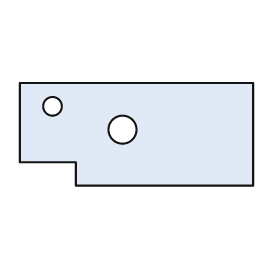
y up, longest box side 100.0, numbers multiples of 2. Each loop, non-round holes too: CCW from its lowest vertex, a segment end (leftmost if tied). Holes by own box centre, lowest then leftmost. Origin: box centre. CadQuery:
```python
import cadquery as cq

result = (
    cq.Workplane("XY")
    .moveTo(-26.0, -22.0)
    .lineTo(50.0, -22.0)
    .lineTo(50.0, 22.0)
    .lineTo(-50.0, 22.0)
    .lineTo(-50.0, -12.0)
    .lineTo(-26.0, -12.0)
    .close()
    .moveTo(-6.0, 2.0)
    .circle(6.0)
    .moveTo(-36.0, 12.0)
    .circle(4.0)
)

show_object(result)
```